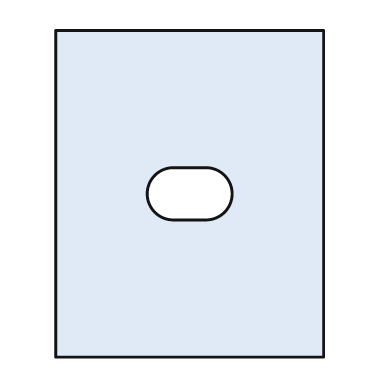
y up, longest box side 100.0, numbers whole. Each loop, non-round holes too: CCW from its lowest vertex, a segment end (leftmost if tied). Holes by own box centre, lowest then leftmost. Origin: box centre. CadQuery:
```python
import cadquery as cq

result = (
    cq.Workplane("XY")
    .moveTo(-41.0, -50.0)
    .lineTo(41.0, -50.0)
    .lineTo(41.0, 50.0)
    .lineTo(-41.0, 50.0)
    .close()
    .moveTo(-5.0, -8.0)
    .lineTo(5.0, -8.0)
    .threePointArc((13.0, 0.0), (5.0, 8.0))
    .lineTo(-5.0, 8.0)
    .threePointArc((-13.0, 0.0), (-5.0, -8.0))
    .close()
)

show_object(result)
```